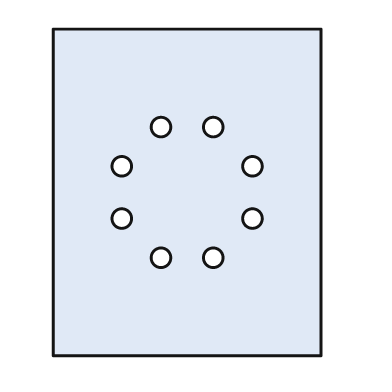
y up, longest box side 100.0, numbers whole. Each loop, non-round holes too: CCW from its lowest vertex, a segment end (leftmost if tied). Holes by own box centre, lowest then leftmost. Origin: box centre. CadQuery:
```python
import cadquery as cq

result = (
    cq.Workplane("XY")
    .moveTo(-41.0, -50.0)
    .lineTo(41.0, -50.0)
    .lineTo(41.0, 50.0)
    .lineTo(-41.0, 50.0)
    .close()
    .moveTo(-8.0, -20.0)
    .circle(3.0)
    .moveTo(8.0, -20.0)
    .circle(3.0)
    .moveTo(-20.0, -8.0)
    .circle(3.0)
    .moveTo(20.0, -8.0)
    .circle(3.0)
    .moveTo(-20.0, 8.0)
    .circle(3.0)
    .moveTo(20.0, 8.0)
    .circle(3.0)
    .moveTo(-8.0, 20.0)
    .circle(3.0)
    .moveTo(8.0, 20.0)
    .circle(3.0)
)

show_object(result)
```